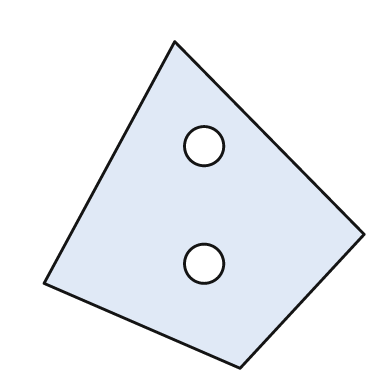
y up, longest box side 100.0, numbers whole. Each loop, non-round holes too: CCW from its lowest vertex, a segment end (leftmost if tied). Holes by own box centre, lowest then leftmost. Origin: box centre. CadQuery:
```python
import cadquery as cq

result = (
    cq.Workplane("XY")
    .moveTo(11.0, -50.0)
    .lineTo(49.0, -9.0)
    .lineTo(-9.0, 50.0)
    .lineTo(-49.0, -24.0)
    .close()
    .moveTo(0.0, -18.0)
    .circle(6.0)
    .moveTo(0.0, 18.0)
    .circle(6.0)
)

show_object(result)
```